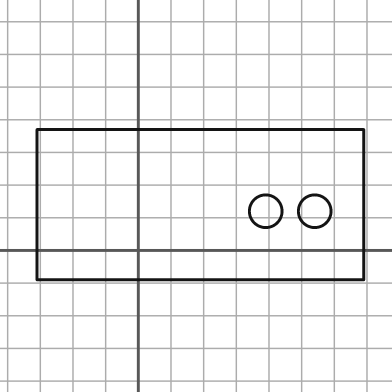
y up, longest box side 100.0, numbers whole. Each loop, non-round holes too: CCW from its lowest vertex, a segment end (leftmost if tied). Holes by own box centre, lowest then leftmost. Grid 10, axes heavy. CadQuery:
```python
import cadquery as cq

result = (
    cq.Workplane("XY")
    .moveTo(-31.0, -9.0)
    .lineTo(69.0, -9.0)
    .lineTo(69.0, 37.0)
    .lineTo(-31.0, 37.0)
    .close()
    .moveTo(39.0, 12.0)
    .circle(5.0)
    .moveTo(54.0, 12.0)
    .circle(5.0)
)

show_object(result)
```